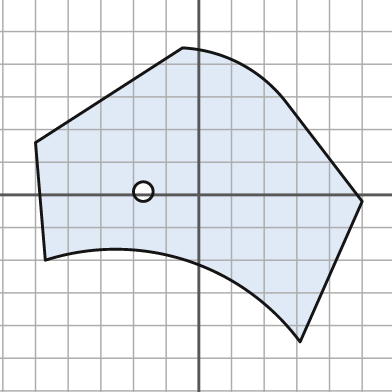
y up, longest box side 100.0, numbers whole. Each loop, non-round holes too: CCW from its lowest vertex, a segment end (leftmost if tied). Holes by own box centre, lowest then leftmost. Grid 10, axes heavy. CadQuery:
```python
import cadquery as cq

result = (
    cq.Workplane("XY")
    .moveTo(31.0, -45.0)
    .lineTo(50.0, -2.0)
    .lineTo(27.0, 28.0)
    .threePointArc((13.0, 40.0), (-5.0, 45.0))
    .lineTo(-50.0, 16.0)
    .lineTo(-47.0, -20.0)
    .threePointArc((-4.0, -20.0), (31.0, -45.0))
    .close()
    .moveTo(-17.0, 1.0)
    .circle(3.0)
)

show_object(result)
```